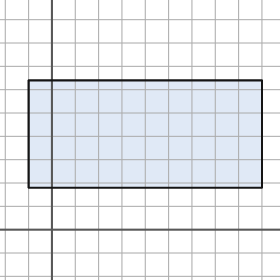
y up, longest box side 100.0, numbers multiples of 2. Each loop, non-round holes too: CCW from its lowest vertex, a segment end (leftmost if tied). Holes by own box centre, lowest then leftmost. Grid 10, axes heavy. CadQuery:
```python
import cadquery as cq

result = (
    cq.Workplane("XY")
    .moveTo(-10.0, 18.0)
    .lineTo(90.0, 18.0)
    .lineTo(90.0, 64.0)
    .lineTo(-10.0, 64.0)
    .close()
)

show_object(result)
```